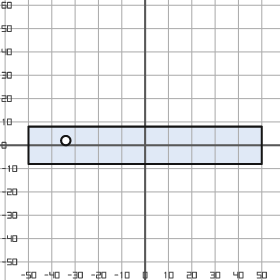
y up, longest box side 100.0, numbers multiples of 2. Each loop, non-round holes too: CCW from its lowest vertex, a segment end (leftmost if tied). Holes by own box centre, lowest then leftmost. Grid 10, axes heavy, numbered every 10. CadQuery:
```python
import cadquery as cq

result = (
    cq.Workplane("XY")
    .moveTo(-50.0, -8.0)
    .lineTo(50.0, -8.0)
    .lineTo(50.0, 8.0)
    .lineTo(-50.0, 8.0)
    .close()
    .moveTo(-34.0, 2.0)
    .circle(2.0)
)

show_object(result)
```